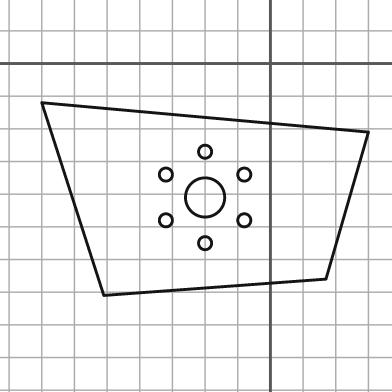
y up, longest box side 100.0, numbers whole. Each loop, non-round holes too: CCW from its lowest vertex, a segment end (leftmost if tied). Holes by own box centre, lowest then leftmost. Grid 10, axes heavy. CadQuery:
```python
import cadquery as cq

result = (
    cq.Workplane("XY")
    .moveTo(-51.0, -71.0)
    .lineTo(17.0, -66.0)
    .lineTo(30.0, -21.0)
    .lineTo(-70.0, -12.0)
    .close()
    .moveTo(-20.0, -55.0)
    .circle(2.0)
    .moveTo(-32.0, -48.0)
    .circle(2.0)
    .moveTo(-8.0, -48.0)
    .circle(2.0)
    .moveTo(-20.0, -41.0)
    .circle(6.0)
    .moveTo(-32.0, -34.0)
    .circle(2.0)
    .moveTo(-8.0, -34.0)
    .circle(2.0)
    .moveTo(-20.0, -27.0)
    .circle(2.0)
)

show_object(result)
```